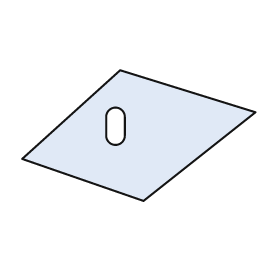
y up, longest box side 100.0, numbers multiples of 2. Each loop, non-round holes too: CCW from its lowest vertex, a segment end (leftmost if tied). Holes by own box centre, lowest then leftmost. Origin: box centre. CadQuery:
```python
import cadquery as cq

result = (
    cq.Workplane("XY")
    .moveTo(2.0, -28.0)
    .lineTo(50.0, 10.0)
    .lineTo(-8.0, 28.0)
    .lineTo(-50.0, -10.0)
    .close()
    .moveTo(-14.0, 0.0)
    .threePointArc((-10.0, -4.0), (-6.0, 0.0))
    .lineTo(-6.0, 8.0)
    .threePointArc((-10.0, 12.0), (-14.0, 8.0))
    .close()
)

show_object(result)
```